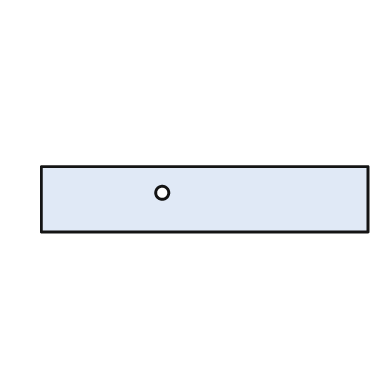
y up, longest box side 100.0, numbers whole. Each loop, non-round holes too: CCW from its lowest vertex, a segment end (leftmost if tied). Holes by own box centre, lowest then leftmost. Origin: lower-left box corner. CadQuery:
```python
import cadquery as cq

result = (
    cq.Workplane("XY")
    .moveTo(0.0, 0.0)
    .lineTo(100.0, 0.0)
    .lineTo(100.0, 20.0)
    .lineTo(0.0, 20.0)
    .close()
    .moveTo(37.0, 12.0)
    .circle(2.0)
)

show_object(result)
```